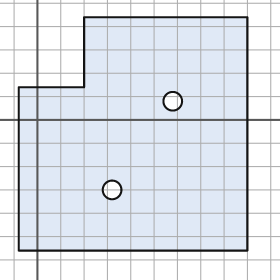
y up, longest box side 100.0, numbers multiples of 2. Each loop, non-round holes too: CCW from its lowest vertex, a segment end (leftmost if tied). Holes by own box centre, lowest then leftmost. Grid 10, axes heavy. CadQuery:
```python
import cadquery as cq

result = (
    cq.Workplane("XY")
    .moveTo(-8.0, -56.0)
    .lineTo(90.0, -56.0)
    .lineTo(90.0, 44.0)
    .lineTo(20.0, 44.0)
    .lineTo(20.0, 14.0)
    .lineTo(-8.0, 14.0)
    .close()
    .moveTo(32.0, -30.0)
    .circle(4.0)
    .moveTo(58.0, 8.0)
    .circle(4.0)
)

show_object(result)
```